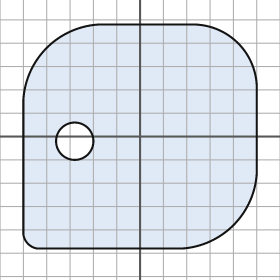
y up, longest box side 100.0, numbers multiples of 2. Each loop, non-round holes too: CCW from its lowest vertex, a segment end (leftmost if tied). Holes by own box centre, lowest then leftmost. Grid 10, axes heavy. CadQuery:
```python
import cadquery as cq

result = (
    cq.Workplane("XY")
    .moveTo(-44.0, -48.0)
    .lineTo(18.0, -48.0)
    .threePointArc((40.0, -38.0), (50.0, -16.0))
    .lineTo(50.0, 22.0)
    .threePointArc((42.0, 40.0), (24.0, 48.0))
    .lineTo(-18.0, 48.0)
    .threePointArc((-40.0, 38.0), (-50.0, 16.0))
    .lineTo(-50.0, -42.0)
    .threePointArc((-48.0, -46.0), (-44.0, -48.0))
    .close()
    .moveTo(-28.0, -2.0)
    .circle(8.0)
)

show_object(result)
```